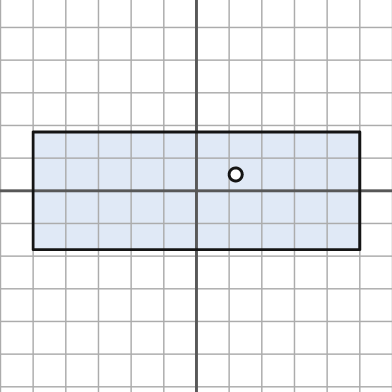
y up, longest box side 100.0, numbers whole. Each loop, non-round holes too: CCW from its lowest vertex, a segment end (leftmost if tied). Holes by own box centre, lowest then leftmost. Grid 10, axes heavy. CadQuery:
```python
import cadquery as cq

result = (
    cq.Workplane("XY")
    .moveTo(-50.0, -18.0)
    .lineTo(50.0, -18.0)
    .lineTo(50.0, 18.0)
    .lineTo(-50.0, 18.0)
    .close()
    .moveTo(12.0, 5.0)
    .circle(2.0)
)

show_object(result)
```